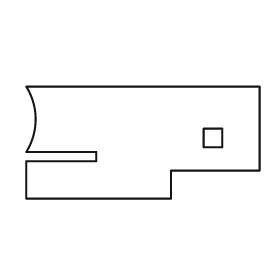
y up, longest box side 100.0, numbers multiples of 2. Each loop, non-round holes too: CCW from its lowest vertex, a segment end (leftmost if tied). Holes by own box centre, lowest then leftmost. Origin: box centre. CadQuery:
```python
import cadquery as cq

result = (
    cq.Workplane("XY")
    .moveTo(-50.0, -24.0)
    .lineTo(12.0, -24.0)
    .lineTo(12.0, -12.0)
    .lineTo(50.0, -12.0)
    .lineTo(50.0, 24.0)
    .lineTo(-50.0, 24.0)
    .threePointArc((-46.0, 10.0), (-50.0, -4.0))
    .lineTo(-20.0, -4.0)
    .lineTo(-20.0, -8.0)
    .lineTo(-50.0, -8.0)
    .close()
    .moveTo(26.0, -2.0)
    .lineTo(34.0, -2.0)
    .lineTo(34.0, 6.0)
    .lineTo(26.0, 6.0)
    .close()
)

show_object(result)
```